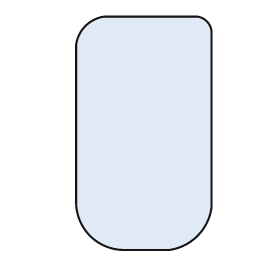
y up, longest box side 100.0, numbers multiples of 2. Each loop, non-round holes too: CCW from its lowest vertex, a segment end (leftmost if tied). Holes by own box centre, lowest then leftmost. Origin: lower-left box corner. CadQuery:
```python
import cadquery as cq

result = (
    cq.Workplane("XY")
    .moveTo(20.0, 0.0)
    .lineTo(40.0, 0.0)
    .threePointArc((52.0, 6.0), (58.0, 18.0))
    .lineTo(58.0, 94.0)
    .threePointArc((56.0, 98.0), (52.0, 100.0))
    .lineTo(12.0, 100.0)
    .threePointArc((4.0, 96.0), (0.0, 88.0))
    .lineTo(0.0, 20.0)
    .threePointArc((6.0, 6.0), (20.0, 0.0))
    .close()
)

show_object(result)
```